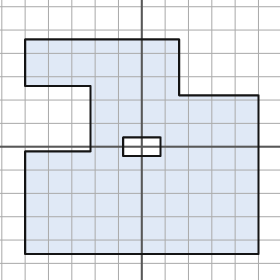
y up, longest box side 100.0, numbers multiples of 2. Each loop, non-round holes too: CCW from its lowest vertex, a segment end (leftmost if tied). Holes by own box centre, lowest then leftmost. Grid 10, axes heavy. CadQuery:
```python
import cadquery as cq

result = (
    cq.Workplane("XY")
    .moveTo(-50.0, -46.0)
    .lineTo(50.0, -46.0)
    .lineTo(50.0, 22.0)
    .lineTo(16.0, 22.0)
    .lineTo(16.0, 46.0)
    .lineTo(-50.0, 46.0)
    .lineTo(-50.0, 26.0)
    .lineTo(-22.0, 26.0)
    .lineTo(-22.0, -2.0)
    .lineTo(-50.0, -2.0)
    .close()
    .moveTo(-8.0, -4.0)
    .lineTo(8.0, -4.0)
    .lineTo(8.0, 4.0)
    .lineTo(-8.0, 4.0)
    .close()
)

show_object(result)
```